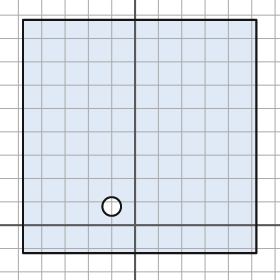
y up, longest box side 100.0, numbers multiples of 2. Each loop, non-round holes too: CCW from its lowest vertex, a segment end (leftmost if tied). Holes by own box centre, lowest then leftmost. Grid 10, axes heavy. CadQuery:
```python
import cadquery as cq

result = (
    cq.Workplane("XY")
    .moveTo(-48.0, -12.0)
    .lineTo(52.0, -12.0)
    .lineTo(52.0, 88.0)
    .lineTo(-48.0, 88.0)
    .close()
    .moveTo(-10.0, 8.0)
    .circle(4.0)
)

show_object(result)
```